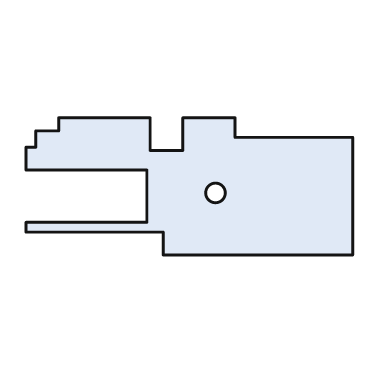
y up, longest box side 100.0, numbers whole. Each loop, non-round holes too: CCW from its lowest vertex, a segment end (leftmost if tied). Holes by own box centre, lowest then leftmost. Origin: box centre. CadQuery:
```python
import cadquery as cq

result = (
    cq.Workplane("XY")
    .moveTo(-8.0, -21.0)
    .lineTo(50.0, -21.0)
    .lineTo(50.0, 15.0)
    .lineTo(14.0, 15.0)
    .lineTo(14.0, 21.0)
    .lineTo(-2.0, 21.0)
    .lineTo(-2.0, 11.0)
    .lineTo(-12.0, 11.0)
    .lineTo(-12.0, 21.0)
    .lineTo(-40.0, 21.0)
    .lineTo(-40.0, 17.0)
    .lineTo(-47.0, 17.0)
    .lineTo(-47.0, 12.0)
    .lineTo(-50.0, 12.0)
    .lineTo(-50.0, 5.0)
    .lineTo(-13.0, 5.0)
    .lineTo(-13.0, -11.0)
    .lineTo(-50.0, -11.0)
    .lineTo(-50.0, -14.0)
    .lineTo(-8.0, -14.0)
    .close()
    .moveTo(8.0, -2.0)
    .circle(3.0)
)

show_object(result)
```